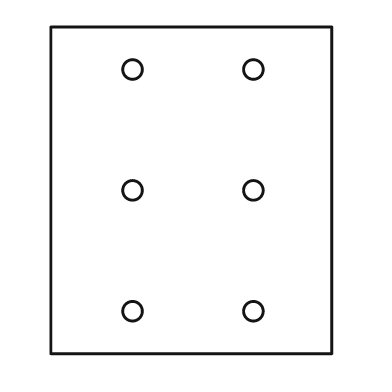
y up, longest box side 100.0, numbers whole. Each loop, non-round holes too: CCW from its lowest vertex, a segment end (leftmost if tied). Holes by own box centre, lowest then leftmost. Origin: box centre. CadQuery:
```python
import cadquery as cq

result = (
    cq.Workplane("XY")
    .moveTo(-43.0, -50.0)
    .lineTo(43.0, -50.0)
    .lineTo(43.0, 50.0)
    .lineTo(-43.0, 50.0)
    .close()
    .moveTo(-18.0, -37.0)
    .circle(3.0)
    .moveTo(19.0, -37.0)
    .circle(3.0)
    .moveTo(-18.0, 0.0)
    .circle(3.0)
    .moveTo(19.0, 0.0)
    .circle(3.0)
    .moveTo(-18.0, 37.0)
    .circle(3.0)
    .moveTo(19.0, 37.0)
    .circle(3.0)
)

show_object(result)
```